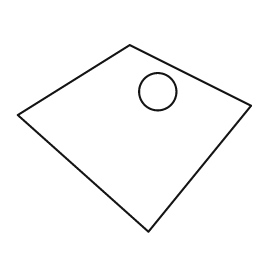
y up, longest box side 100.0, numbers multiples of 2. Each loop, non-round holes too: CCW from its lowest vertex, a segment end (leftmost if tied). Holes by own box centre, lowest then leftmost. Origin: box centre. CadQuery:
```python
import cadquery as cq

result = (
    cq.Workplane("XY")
    .moveTo(6.0, -40.0)
    .lineTo(50.0, 14.0)
    .lineTo(-2.0, 40.0)
    .lineTo(-50.0, 10.0)
    .close()
    .moveTo(10.0, 20.0)
    .circle(8.0)
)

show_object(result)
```